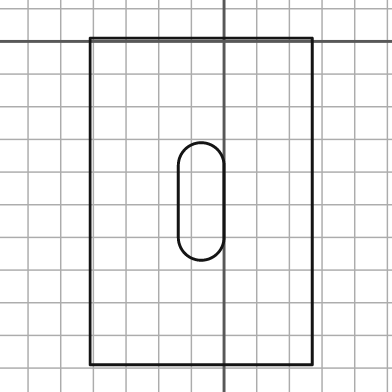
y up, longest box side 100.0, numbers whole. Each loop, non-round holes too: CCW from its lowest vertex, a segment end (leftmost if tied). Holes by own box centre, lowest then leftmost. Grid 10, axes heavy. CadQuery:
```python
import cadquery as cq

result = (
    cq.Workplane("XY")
    .moveTo(-41.0, -99.0)
    .lineTo(27.0, -99.0)
    .lineTo(27.0, 1.0)
    .lineTo(-41.0, 1.0)
    .close()
    .moveTo(-14.0, -60.0)
    .threePointArc((-7.0, -67.0), (0.0, -60.0))
    .lineTo(0.0, -38.0)
    .threePointArc((-7.0, -31.0), (-14.0, -38.0))
    .close()
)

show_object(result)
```